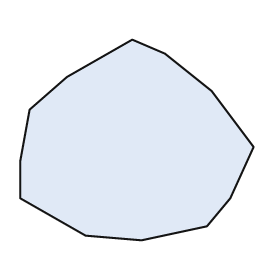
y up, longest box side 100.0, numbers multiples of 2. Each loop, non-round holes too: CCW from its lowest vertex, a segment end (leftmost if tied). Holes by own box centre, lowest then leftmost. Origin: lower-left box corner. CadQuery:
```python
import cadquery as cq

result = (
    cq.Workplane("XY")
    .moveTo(52.0, 0.0)
    .lineTo(80.0, 6.0)
    .lineTo(90.0, 18.0)
    .lineTo(100.0, 40.0)
    .lineTo(82.0, 64.0)
    .lineTo(62.0, 80.0)
    .lineTo(48.0, 86.0)
    .lineTo(20.0, 70.0)
    .lineTo(4.0, 56.0)
    .lineTo(0.0, 34.0)
    .lineTo(0.0, 18.0)
    .lineTo(28.0, 2.0)
    .close()
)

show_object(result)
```